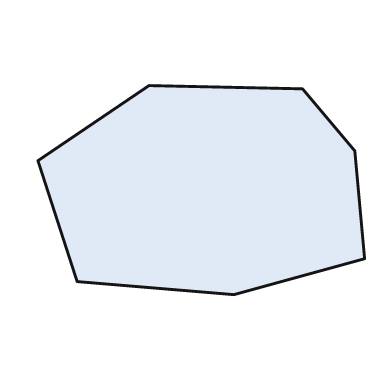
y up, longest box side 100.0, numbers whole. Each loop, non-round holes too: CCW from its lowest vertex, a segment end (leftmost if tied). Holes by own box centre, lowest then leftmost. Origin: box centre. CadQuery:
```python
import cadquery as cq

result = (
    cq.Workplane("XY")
    .moveTo(10.0, -32.0)
    .lineTo(50.0, -21.0)
    .lineTo(47.0, 12.0)
    .lineTo(31.0, 31.0)
    .lineTo(-16.0, 32.0)
    .lineTo(-50.0, 9.0)
    .lineTo(-38.0, -28.0)
    .close()
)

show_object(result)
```